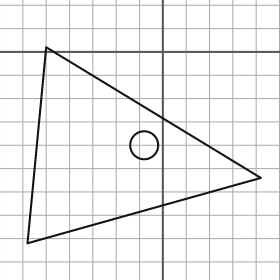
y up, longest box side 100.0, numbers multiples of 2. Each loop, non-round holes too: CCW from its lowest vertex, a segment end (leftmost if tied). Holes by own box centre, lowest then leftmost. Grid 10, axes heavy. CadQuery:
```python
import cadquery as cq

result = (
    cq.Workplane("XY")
    .moveTo(-58.0, -82.0)
    .lineTo(42.0, -54.0)
    .lineTo(-50.0, 2.0)
    .close()
    .moveTo(-8.0, -40.0)
    .circle(6.0)
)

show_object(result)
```